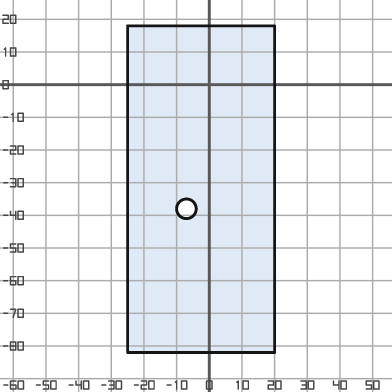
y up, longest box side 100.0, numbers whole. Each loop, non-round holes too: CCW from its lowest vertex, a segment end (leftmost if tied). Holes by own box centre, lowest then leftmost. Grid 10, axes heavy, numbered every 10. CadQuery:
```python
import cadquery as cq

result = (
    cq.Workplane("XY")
    .moveTo(-25.0, -82.0)
    .lineTo(20.0, -82.0)
    .lineTo(20.0, 18.0)
    .lineTo(-25.0, 18.0)
    .close()
    .moveTo(-7.0, -38.0)
    .circle(3.0)
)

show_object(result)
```